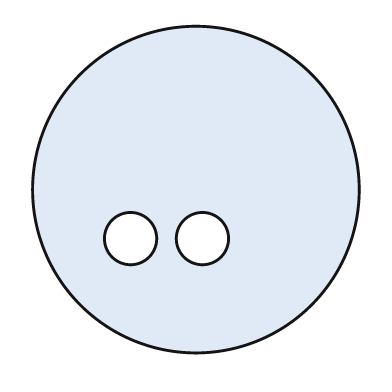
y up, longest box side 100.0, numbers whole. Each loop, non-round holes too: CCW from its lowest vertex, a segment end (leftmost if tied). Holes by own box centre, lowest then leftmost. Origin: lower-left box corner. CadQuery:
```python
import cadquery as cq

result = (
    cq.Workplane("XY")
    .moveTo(50.0, 50.0)
    .circle(50.0)
    .moveTo(30.0, 35.0)
    .circle(8.0)
    .moveTo(52.0, 35.0)
    .circle(8.0)
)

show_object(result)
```